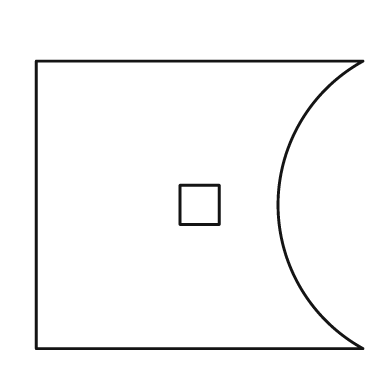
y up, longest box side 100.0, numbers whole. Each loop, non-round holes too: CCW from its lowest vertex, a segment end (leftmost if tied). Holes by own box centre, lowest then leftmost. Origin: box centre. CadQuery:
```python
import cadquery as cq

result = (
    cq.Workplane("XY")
    .moveTo(-50.0, -44.0)
    .lineTo(50.0, -44.0)
    .threePointArc((24.0, 0.0), (50.0, 44.0))
    .lineTo(-50.0, 44.0)
    .close()
    .moveTo(-6.0, -6.0)
    .lineTo(6.0, -6.0)
    .lineTo(6.0, 6.0)
    .lineTo(-6.0, 6.0)
    .close()
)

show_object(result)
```